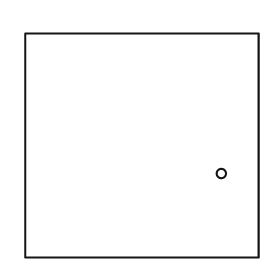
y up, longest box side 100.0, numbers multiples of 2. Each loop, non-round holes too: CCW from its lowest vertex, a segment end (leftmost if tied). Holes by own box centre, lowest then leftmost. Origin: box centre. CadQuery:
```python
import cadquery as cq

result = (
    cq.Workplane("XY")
    .moveTo(-50.0, -48.0)
    .lineTo(50.0, -48.0)
    .lineTo(50.0, 48.0)
    .lineTo(-50.0, 48.0)
    .close()
    .moveTo(34.0, -12.0)
    .circle(2.0)
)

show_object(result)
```